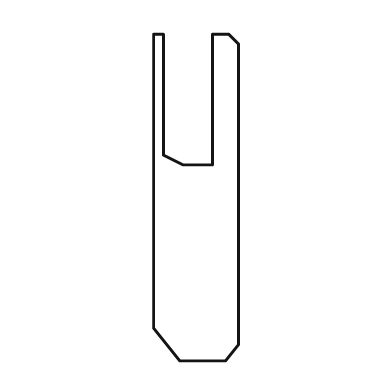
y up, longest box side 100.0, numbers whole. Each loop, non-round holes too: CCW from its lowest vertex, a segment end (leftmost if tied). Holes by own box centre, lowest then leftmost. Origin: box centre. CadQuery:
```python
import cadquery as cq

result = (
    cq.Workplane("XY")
    .moveTo(-5.0, -50.0)
    .lineTo(9.0, -50.0)
    .lineTo(13.0, -45.0)
    .lineTo(13.0, 47.0)
    .lineTo(10.0, 50.0)
    .lineTo(5.0, 50.0)
    .lineTo(5.0, 10.0)
    .lineTo(-4.0, 10.0)
    .lineTo(-10.0, 13.0)
    .lineTo(-10.0, 50.0)
    .lineTo(-13.0, 50.0)
    .lineTo(-13.0, -40.0)
    .close()
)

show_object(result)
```